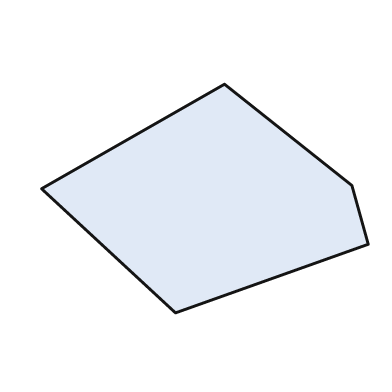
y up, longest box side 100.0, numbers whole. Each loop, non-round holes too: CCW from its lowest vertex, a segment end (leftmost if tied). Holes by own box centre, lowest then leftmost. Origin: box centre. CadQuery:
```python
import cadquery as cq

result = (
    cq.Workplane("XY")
    .moveTo(-9.0, -35.0)
    .lineTo(50.0, -14.0)
    .lineTo(45.0, 4.0)
    .lineTo(6.0, 35.0)
    .lineTo(-50.0, 3.0)
    .close()
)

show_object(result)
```